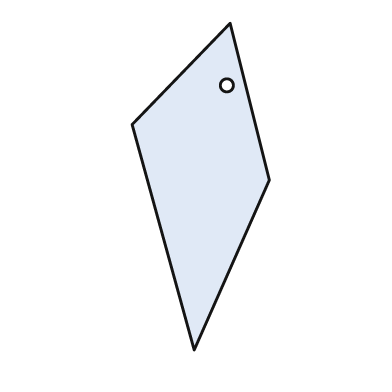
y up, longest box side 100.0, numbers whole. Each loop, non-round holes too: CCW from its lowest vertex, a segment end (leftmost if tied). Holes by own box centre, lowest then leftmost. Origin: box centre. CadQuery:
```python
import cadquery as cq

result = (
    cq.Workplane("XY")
    .moveTo(-2.0, -50.0)
    .lineTo(21.0, 2.0)
    .lineTo(9.0, 50.0)
    .lineTo(-21.0, 19.0)
    .close()
    .moveTo(8.0, 31.0)
    .circle(2.0)
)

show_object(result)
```